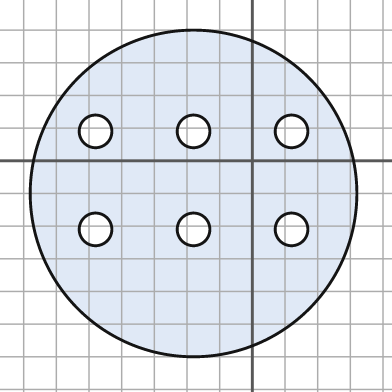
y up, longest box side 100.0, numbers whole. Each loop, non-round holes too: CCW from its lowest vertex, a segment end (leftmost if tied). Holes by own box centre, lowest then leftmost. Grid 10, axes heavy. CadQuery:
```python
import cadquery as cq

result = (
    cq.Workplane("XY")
    .moveTo(-18.0, -10.0)
    .circle(50.0)
    .moveTo(-48.0, -21.0)
    .circle(5.0)
    .moveTo(-18.0, -21.0)
    .circle(5.0)
    .moveTo(12.0, -21.0)
    .circle(5.0)
    .moveTo(-48.0, 9.0)
    .circle(5.0)
    .moveTo(-18.0, 9.0)
    .circle(5.0)
    .moveTo(12.0, 9.0)
    .circle(5.0)
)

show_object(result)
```